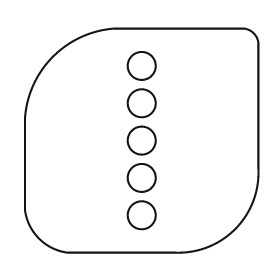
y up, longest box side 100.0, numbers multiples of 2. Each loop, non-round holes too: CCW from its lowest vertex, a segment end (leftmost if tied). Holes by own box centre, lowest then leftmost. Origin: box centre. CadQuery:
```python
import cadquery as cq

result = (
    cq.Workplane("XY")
    .moveTo(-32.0, -48.0)
    .lineTo(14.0, -48.0)
    .threePointArc((40.0, -38.0), (50.0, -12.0))
    .lineTo(50.0, 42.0)
    .threePointArc((48.0, 46.0), (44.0, 48.0))
    .lineTo(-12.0, 48.0)
    .threePointArc((-38.0, 36.0), (-50.0, 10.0))
    .lineTo(-50.0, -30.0)
    .threePointArc((-44.0, -42.0), (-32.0, -48.0))
    .close()
    .moveTo(0.0, -32.0)
    .circle(6.0)
    .moveTo(0.0, -16.0)
    .circle(6.0)
    .moveTo(0.0, 0.0)
    .circle(6.0)
    .moveTo(0.0, 16.0)
    .circle(6.0)
    .moveTo(0.0, 32.0)
    .circle(6.0)
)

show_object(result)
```